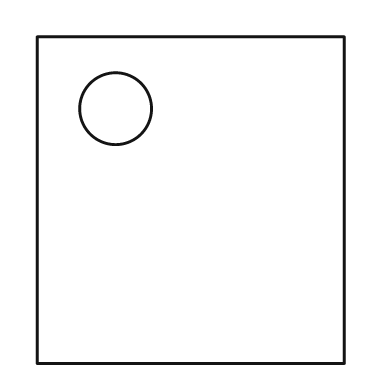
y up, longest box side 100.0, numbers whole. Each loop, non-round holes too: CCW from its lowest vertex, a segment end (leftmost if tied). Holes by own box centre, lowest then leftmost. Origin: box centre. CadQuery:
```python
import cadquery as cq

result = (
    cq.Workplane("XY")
    .moveTo(-47.0, -50.0)
    .lineTo(47.0, -50.0)
    .lineTo(47.0, 50.0)
    .lineTo(-47.0, 50.0)
    .close()
    .moveTo(-23.0, 28.0)
    .circle(11.0)
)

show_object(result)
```